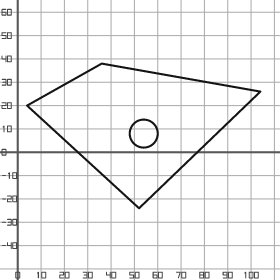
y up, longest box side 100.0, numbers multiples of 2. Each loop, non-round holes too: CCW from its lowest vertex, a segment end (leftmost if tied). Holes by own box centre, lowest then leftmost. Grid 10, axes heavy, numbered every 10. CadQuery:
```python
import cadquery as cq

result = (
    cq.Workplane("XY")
    .moveTo(52.0, -24.0)
    .lineTo(104.0, 26.0)
    .lineTo(36.0, 38.0)
    .lineTo(4.0, 20.0)
    .close()
    .moveTo(54.0, 8.0)
    .circle(6.0)
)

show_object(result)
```